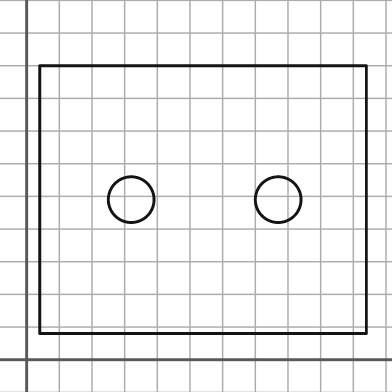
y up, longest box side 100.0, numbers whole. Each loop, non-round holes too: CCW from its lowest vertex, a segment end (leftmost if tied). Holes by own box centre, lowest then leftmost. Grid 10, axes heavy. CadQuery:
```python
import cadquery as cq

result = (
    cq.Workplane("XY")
    .moveTo(4.0, 8.0)
    .lineTo(104.0, 8.0)
    .lineTo(104.0, 90.0)
    .lineTo(4.0, 90.0)
    .close()
    .moveTo(32.0, 49.0)
    .circle(7.0)
    .moveTo(77.0, 49.0)
    .circle(7.0)
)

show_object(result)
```